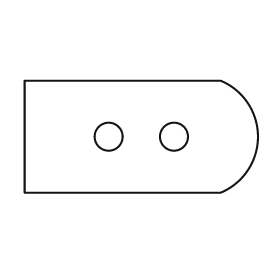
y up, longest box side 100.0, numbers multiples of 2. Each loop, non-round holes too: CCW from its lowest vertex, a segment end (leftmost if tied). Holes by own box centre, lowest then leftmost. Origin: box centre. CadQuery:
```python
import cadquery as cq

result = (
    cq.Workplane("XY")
    .moveTo(-50.0, -24.0)
    .lineTo(34.0, -24.0)
    .threePointArc((50.0, 0.0), (34.0, 24.0))
    .lineTo(-50.0, 24.0)
    .close()
    .moveTo(-14.0, 0.0)
    .circle(6.0)
    .moveTo(14.0, 0.0)
    .circle(6.0)
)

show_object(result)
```